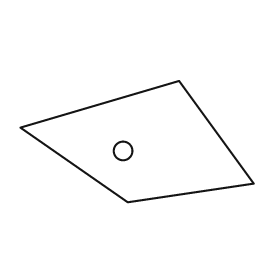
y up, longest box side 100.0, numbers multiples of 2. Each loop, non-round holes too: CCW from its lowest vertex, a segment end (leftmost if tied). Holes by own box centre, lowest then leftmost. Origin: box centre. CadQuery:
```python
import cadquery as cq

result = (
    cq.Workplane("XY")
    .moveTo(-4.0, -26.0)
    .lineTo(50.0, -18.0)
    .lineTo(18.0, 26.0)
    .lineTo(-50.0, 6.0)
    .close()
    .moveTo(-6.0, -4.0)
    .circle(4.0)
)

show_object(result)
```